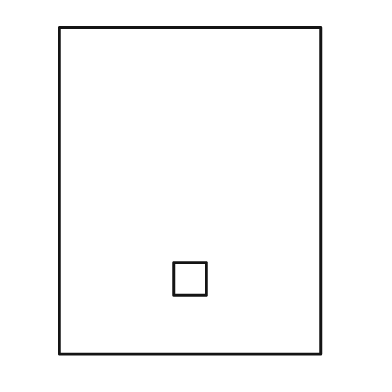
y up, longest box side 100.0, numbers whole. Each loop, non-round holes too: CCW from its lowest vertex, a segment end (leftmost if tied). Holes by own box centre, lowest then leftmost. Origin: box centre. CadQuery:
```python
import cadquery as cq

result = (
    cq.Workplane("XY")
    .moveTo(-40.0, -50.0)
    .lineTo(40.0, -50.0)
    .lineTo(40.0, 50.0)
    .lineTo(-40.0, 50.0)
    .close()
    .moveTo(-5.0, -32.0)
    .lineTo(5.0, -32.0)
    .lineTo(5.0, -22.0)
    .lineTo(-5.0, -22.0)
    .close()
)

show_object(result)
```